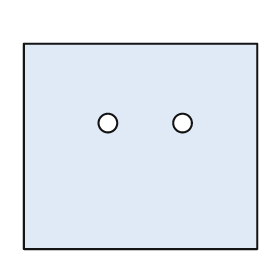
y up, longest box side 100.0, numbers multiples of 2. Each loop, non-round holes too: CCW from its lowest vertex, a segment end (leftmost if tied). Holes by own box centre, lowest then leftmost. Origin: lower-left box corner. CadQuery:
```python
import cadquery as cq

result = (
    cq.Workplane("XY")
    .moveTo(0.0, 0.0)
    .lineTo(100.0, 0.0)
    .lineTo(100.0, 88.0)
    .lineTo(0.0, 88.0)
    .close()
    .moveTo(36.0, 54.0)
    .circle(4.0)
    .moveTo(68.0, 54.0)
    .circle(4.0)
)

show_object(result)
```